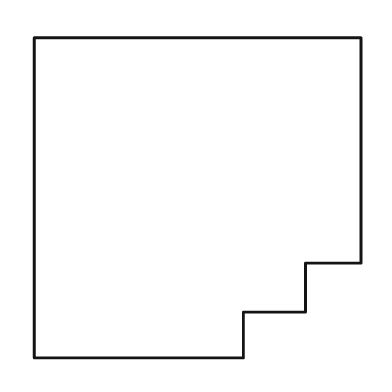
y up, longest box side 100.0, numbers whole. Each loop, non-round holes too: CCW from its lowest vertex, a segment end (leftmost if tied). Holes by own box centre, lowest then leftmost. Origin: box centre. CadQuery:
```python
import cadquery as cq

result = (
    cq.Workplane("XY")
    .moveTo(-50.0, -49.0)
    .lineTo(14.0, -49.0)
    .lineTo(14.0, -35.0)
    .lineTo(33.0, -35.0)
    .lineTo(33.0, -20.0)
    .lineTo(50.0, -20.0)
    .lineTo(50.0, 49.0)
    .lineTo(-50.0, 49.0)
    .close()
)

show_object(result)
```